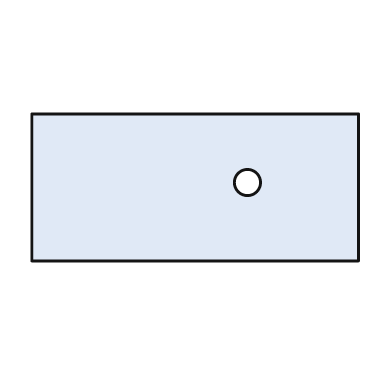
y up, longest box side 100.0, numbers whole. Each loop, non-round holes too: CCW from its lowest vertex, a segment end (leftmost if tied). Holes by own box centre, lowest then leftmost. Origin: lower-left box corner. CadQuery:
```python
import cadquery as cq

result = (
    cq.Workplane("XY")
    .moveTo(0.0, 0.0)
    .lineTo(100.0, 0.0)
    .lineTo(100.0, 45.0)
    .lineTo(0.0, 45.0)
    .close()
    .moveTo(66.0, 24.0)
    .circle(4.0)
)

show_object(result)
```